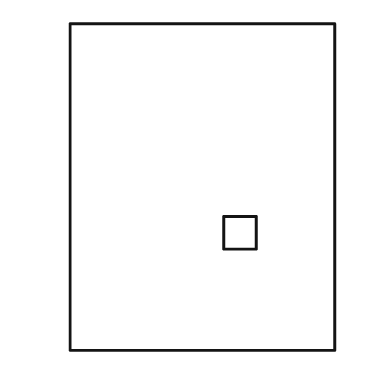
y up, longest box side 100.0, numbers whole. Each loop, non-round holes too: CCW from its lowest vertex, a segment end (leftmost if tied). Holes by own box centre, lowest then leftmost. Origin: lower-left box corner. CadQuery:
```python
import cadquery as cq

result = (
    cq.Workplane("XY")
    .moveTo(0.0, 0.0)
    .lineTo(81.0, 0.0)
    .lineTo(81.0, 100.0)
    .lineTo(0.0, 100.0)
    .close()
    .moveTo(47.0, 31.0)
    .lineTo(57.0, 31.0)
    .lineTo(57.0, 41.0)
    .lineTo(47.0, 41.0)
    .close()
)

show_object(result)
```